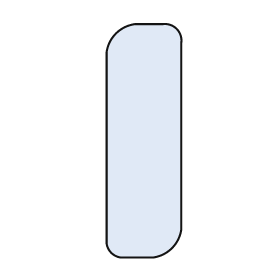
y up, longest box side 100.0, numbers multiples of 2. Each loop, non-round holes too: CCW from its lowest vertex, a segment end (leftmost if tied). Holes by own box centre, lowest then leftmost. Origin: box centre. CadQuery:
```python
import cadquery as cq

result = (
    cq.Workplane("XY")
    .moveTo(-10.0, -50.0)
    .lineTo(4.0, -50.0)
    .threePointArc((12.0, -46.0), (16.0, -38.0))
    .lineTo(16.0, 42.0)
    .threePointArc((14.0, 48.0), (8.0, 50.0))
    .lineTo(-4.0, 50.0)
    .threePointArc((-12.0, 46.0), (-16.0, 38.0))
    .lineTo(-16.0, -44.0)
    .threePointArc((-14.0, -48.0), (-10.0, -50.0))
    .close()
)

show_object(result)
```